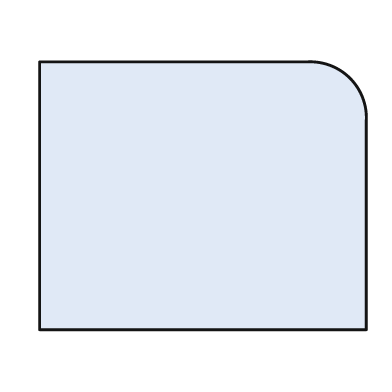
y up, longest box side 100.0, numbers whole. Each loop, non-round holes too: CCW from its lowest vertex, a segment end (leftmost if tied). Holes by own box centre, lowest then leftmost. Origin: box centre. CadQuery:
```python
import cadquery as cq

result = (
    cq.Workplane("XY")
    .moveTo(-50.0, -41.0)
    .lineTo(50.0, -41.0)
    .lineTo(50.0, 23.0)
    .threePointArc((45.0, 36.0), (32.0, 41.0))
    .lineTo(-50.0, 41.0)
    .close()
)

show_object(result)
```